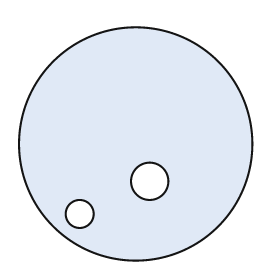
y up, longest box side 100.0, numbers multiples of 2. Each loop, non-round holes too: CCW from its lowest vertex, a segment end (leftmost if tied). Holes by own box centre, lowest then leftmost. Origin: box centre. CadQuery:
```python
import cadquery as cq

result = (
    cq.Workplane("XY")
    .moveTo(0.0, 0.0)
    .circle(50.0)
    .moveTo(-24.0, -30.0)
    .circle(6.0)
    .moveTo(6.0, -16.0)
    .circle(8.0)
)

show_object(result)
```